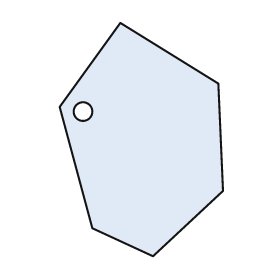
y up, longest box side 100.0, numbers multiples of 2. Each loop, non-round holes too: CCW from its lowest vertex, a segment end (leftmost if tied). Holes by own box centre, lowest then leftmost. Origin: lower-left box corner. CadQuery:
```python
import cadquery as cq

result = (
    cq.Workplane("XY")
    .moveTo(40.0, 0.0)
    .lineTo(70.0, 28.0)
    .lineTo(68.0, 74.0)
    .lineTo(26.0, 100.0)
    .lineTo(0.0, 64.0)
    .lineTo(14.0, 12.0)
    .close()
    .moveTo(10.0, 62.0)
    .circle(4.0)
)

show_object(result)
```